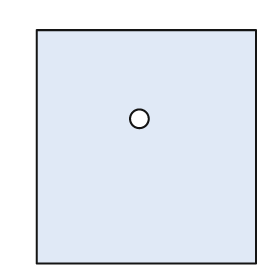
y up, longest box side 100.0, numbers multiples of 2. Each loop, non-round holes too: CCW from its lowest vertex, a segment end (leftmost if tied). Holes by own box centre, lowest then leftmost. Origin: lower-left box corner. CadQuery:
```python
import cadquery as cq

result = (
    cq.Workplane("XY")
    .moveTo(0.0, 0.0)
    .lineTo(94.0, 0.0)
    .lineTo(94.0, 100.0)
    .lineTo(0.0, 100.0)
    .close()
    .moveTo(44.0, 62.0)
    .circle(4.0)
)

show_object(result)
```